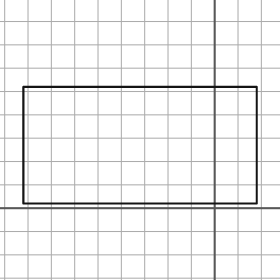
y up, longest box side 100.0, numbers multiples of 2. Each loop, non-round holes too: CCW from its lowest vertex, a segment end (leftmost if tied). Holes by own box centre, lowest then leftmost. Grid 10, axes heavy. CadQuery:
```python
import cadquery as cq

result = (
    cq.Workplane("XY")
    .moveTo(-82.0, 2.0)
    .lineTo(18.0, 2.0)
    .lineTo(18.0, 52.0)
    .lineTo(-82.0, 52.0)
    .close()
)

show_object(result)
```